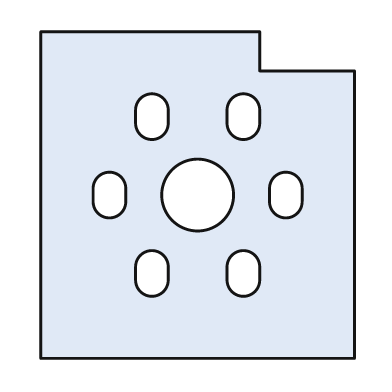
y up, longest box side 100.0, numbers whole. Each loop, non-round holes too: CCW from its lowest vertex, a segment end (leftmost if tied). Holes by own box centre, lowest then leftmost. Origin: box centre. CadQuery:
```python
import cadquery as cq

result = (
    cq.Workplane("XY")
    .moveTo(-48.0, -50.0)
    .lineTo(48.0, -50.0)
    .lineTo(48.0, 38.0)
    .lineTo(19.0, 38.0)
    .lineTo(19.0, 50.0)
    .lineTo(-48.0, 50.0)
    .close()
    .moveTo(-19.0, -26.0)
    .threePointArc((-14.0, -31.0), (-9.0, -26.0))
    .lineTo(-9.0, -22.0)
    .threePointArc((-14.0, -17.0), (-19.0, -22.0))
    .close()
    .moveTo(9.0, -26.0)
    .threePointArc((14.0, -31.0), (19.0, -26.0))
    .lineTo(19.0, -22.0)
    .threePointArc((14.0, -17.0), (9.0, -22.0))
    .close()
    .moveTo(-32.0, -2.0)
    .threePointArc((-27.0, -7.0), (-22.0, -2.0))
    .lineTo(-22.0, 2.0)
    .threePointArc((-27.0, 7.0), (-32.0, 2.0))
    .close()
    .moveTo(0.0, 0.0)
    .circle(11.0)
    .moveTo(22.0, -2.0)
    .threePointArc((27.0, -7.0), (32.0, -2.0))
    .lineTo(32.0, 2.0)
    .threePointArc((27.0, 7.0), (22.0, 2.0))
    .close()
    .moveTo(-19.0, 22.0)
    .threePointArc((-14.0, 17.0), (-9.0, 22.0))
    .lineTo(-9.0, 26.0)
    .threePointArc((-14.0, 31.0), (-19.0, 26.0))
    .close()
    .moveTo(9.0, 22.0)
    .threePointArc((14.0, 17.0), (19.0, 22.0))
    .lineTo(19.0, 26.0)
    .threePointArc((14.0, 31.0), (9.0, 26.0))
    .close()
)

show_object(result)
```